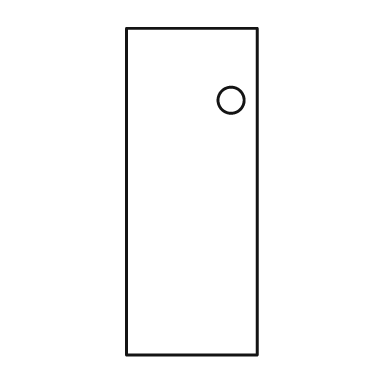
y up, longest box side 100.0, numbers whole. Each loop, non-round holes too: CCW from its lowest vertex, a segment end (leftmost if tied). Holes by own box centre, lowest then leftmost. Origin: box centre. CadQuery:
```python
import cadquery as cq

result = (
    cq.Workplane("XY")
    .moveTo(-20.0, -50.0)
    .lineTo(20.0, -50.0)
    .lineTo(20.0, 50.0)
    .lineTo(-20.0, 50.0)
    .close()
    .moveTo(12.0, 28.0)
    .circle(4.0)
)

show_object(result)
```